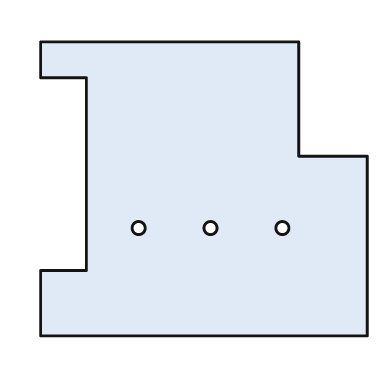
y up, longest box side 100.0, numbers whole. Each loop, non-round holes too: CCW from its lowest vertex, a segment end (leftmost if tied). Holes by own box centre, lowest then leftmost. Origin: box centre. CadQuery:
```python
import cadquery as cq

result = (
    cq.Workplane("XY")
    .moveTo(-50.0, -45.0)
    .lineTo(50.0, -45.0)
    .lineTo(50.0, 10.0)
    .lineTo(29.0, 10.0)
    .lineTo(29.0, 45.0)
    .lineTo(-50.0, 45.0)
    .lineTo(-50.0, 34.0)
    .lineTo(-36.0, 34.0)
    .lineTo(-36.0, -25.0)
    .lineTo(-50.0, -25.0)
    .close()
    .moveTo(-20.0, -12.0)
    .circle(2.0)
    .moveTo(2.0, -12.0)
    .circle(2.0)
    .moveTo(24.0, -12.0)
    .circle(2.0)
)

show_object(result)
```